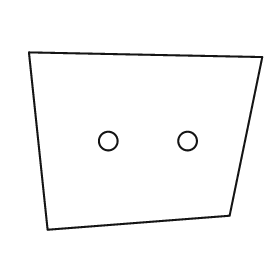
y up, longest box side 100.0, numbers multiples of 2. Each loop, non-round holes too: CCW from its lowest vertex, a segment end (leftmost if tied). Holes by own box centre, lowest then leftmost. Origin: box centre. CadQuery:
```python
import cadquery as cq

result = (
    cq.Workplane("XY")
    .moveTo(-42.0, -38.0)
    .lineTo(36.0, -32.0)
    .lineTo(50.0, 36.0)
    .lineTo(-50.0, 38.0)
    .close()
    .moveTo(-16.0, 0.0)
    .circle(4.0)
    .moveTo(18.0, 0.0)
    .circle(4.0)
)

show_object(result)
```